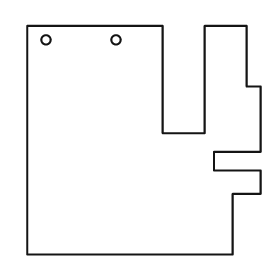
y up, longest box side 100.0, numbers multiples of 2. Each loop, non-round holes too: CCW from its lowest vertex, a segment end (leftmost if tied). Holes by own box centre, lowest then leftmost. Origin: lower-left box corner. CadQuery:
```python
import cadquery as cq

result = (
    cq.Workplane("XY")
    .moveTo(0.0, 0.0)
    .lineTo(88.0, 0.0)
    .lineTo(88.0, 26.0)
    .lineTo(100.0, 26.0)
    .lineTo(100.0, 36.0)
    .lineTo(80.0, 36.0)
    .lineTo(80.0, 44.0)
    .lineTo(100.0, 44.0)
    .lineTo(100.0, 72.0)
    .lineTo(94.0, 72.0)
    .lineTo(94.0, 98.0)
    .lineTo(76.0, 98.0)
    .lineTo(76.0, 52.0)
    .lineTo(58.0, 52.0)
    .lineTo(58.0, 98.0)
    .lineTo(0.0, 98.0)
    .close()
    .moveTo(8.0, 92.0)
    .circle(2.0)
    .moveTo(38.0, 92.0)
    .circle(2.0)
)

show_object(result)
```